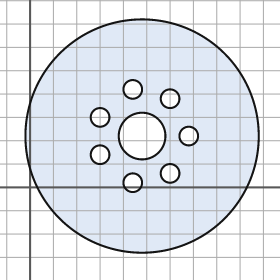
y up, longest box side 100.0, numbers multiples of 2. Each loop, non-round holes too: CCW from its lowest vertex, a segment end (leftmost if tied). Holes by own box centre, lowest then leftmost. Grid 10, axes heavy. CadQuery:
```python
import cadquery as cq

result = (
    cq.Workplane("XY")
    .moveTo(48.0, 22.0)
    .circle(50.0)
    .moveTo(44.0, 2.0)
    .circle(4.0)
    .moveTo(60.0, 6.0)
    .circle(4.0)
    .moveTo(30.0, 14.0)
    .circle(4.0)
    .moveTo(48.0, 22.0)
    .circle(10.0)
    .moveTo(68.0, 22.0)
    .circle(4.0)
    .moveTo(30.0, 30.0)
    .circle(4.0)
    .moveTo(60.0, 38.0)
    .circle(4.0)
    .moveTo(44.0, 42.0)
    .circle(4.0)
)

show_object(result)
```